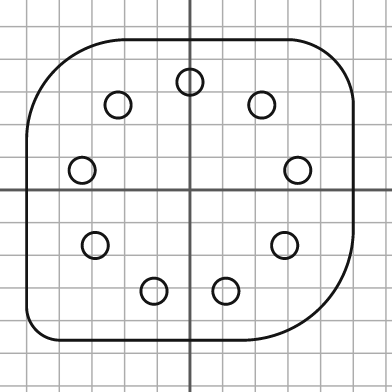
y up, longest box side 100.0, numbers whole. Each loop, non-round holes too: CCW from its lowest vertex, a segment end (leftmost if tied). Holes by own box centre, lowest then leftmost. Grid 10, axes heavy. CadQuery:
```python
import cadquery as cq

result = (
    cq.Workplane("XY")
    .moveTo(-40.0, -46.0)
    .lineTo(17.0, -46.0)
    .threePointArc((40.0, -36.0), (50.0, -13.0))
    .lineTo(50.0, 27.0)
    .threePointArc((44.0, 40.0), (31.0, 46.0))
    .lineTo(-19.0, 46.0)
    .threePointArc((-41.0, 37.0), (-50.0, 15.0))
    .lineTo(-50.0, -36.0)
    .threePointArc((-47.0, -43.0), (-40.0, -46.0))
    .close()
    .moveTo(-11.0, -31.0)
    .circle(4.0)
    .moveTo(11.0, -31.0)
    .circle(4.0)
    .moveTo(-29.0, -17.0)
    .circle(4.0)
    .moveTo(29.0, -17.0)
    .circle(4.0)
    .moveTo(-33.0, 6.0)
    .circle(4.0)
    .moveTo(33.0, 6.0)
    .circle(4.0)
    .moveTo(-22.0, 26.0)
    .circle(4.0)
    .moveTo(22.0, 26.0)
    .circle(4.0)
    .moveTo(0.0, 33.0)
    .circle(4.0)
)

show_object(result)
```